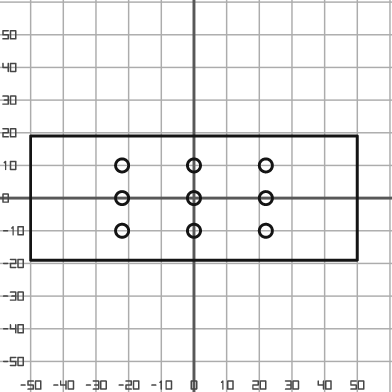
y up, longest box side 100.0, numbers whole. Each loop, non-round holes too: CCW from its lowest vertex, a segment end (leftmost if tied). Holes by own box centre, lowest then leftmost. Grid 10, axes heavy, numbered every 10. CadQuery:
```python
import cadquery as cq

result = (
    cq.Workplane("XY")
    .moveTo(-50.0, -19.0)
    .lineTo(50.0, -19.0)
    .lineTo(50.0, 19.0)
    .lineTo(-50.0, 19.0)
    .close()
    .moveTo(-22.0, -10.0)
    .circle(2.0)
    .moveTo(0.0, -10.0)
    .circle(2.0)
    .moveTo(22.0, -10.0)
    .circle(2.0)
    .moveTo(-22.0, 0.0)
    .circle(2.0)
    .moveTo(0.0, 0.0)
    .circle(2.0)
    .moveTo(22.0, 0.0)
    .circle(2.0)
    .moveTo(-22.0, 10.0)
    .circle(2.0)
    .moveTo(0.0, 10.0)
    .circle(2.0)
    .moveTo(22.0, 10.0)
    .circle(2.0)
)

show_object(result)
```